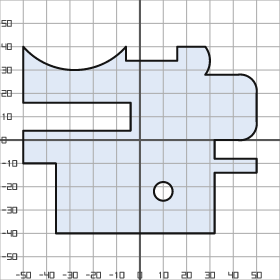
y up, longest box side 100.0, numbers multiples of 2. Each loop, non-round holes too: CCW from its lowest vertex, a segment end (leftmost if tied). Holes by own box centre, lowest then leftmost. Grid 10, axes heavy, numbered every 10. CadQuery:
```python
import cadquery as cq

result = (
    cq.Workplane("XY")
    .moveTo(-36.0, -40.0)
    .lineTo(32.0, -40.0)
    .lineTo(32.0, -14.0)
    .lineTo(50.0, -14.0)
    .lineTo(50.0, -8.0)
    .lineTo(32.0, -8.0)
    .lineTo(32.0, 0.0)
    .lineTo(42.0, 0.0)
    .threePointArc((48.0, 2.0), (50.0, 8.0))
    .lineTo(50.0, 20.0)
    .threePointArc((48.0, 26.0), (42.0, 28.0))
    .lineTo(28.0, 28.0)
    .threePointArc((30.0, 34.0), (28.0, 40.0))
    .lineTo(16.0, 40.0)
    .lineTo(16.0, 34.0)
    .lineTo(-6.0, 34.0)
    .lineTo(-6.0, 40.0)
    .threePointArc((-28.0, 30.0), (-50.0, 40.0))
    .lineTo(-50.0, 16.0)
    .lineTo(-4.0, 16.0)
    .lineTo(-4.0, 4.0)
    .lineTo(-50.0, 4.0)
    .lineTo(-50.0, -10.0)
    .lineTo(-36.0, -10.0)
    .close()
    .moveTo(10.0, -22.0)
    .circle(4.0)
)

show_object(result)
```